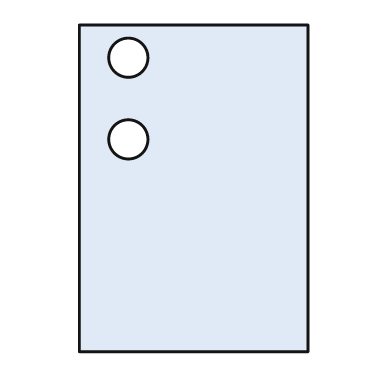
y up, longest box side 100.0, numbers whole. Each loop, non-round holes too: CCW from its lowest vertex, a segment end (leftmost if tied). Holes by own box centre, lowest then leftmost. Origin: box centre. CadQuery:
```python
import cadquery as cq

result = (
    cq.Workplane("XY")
    .moveTo(-35.0, -50.0)
    .lineTo(35.0, -50.0)
    .lineTo(35.0, 50.0)
    .lineTo(-35.0, 50.0)
    .close()
    .moveTo(-20.0, 15.0)
    .circle(6.0)
    .moveTo(-20.0, 40.0)
    .circle(6.0)
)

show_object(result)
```